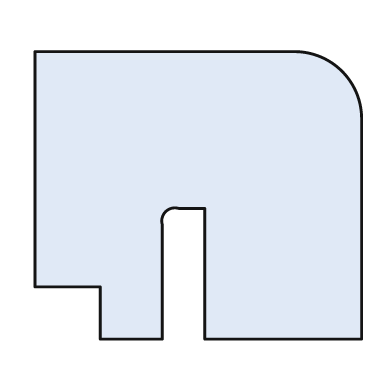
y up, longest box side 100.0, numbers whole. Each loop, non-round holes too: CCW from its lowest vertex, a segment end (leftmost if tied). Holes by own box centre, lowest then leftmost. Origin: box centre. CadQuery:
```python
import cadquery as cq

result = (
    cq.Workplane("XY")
    .moveTo(-30.0, -44.0)
    .lineTo(-11.0, -44.0)
    .lineTo(-11.0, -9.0)
    .threePointArc((-10.0, -5.0), (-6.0, -4.0))
    .lineTo(2.0, -4.0)
    .lineTo(2.0, -44.0)
    .lineTo(50.0, -44.0)
    .lineTo(50.0, 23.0)
    .threePointArc((44.0, 38.0), (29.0, 44.0))
    .lineTo(-50.0, 44.0)
    .lineTo(-50.0, -28.0)
    .lineTo(-30.0, -28.0)
    .close()
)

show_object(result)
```